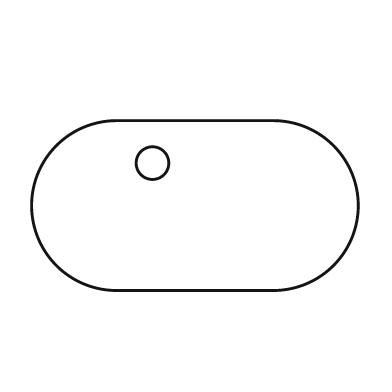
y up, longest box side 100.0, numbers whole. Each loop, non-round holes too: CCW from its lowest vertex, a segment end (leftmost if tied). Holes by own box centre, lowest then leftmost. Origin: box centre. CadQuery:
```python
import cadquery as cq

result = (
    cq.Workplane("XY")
    .moveTo(-24.0, -26.0)
    .lineTo(24.0, -26.0)
    .threePointArc((50.0, 0.0), (24.0, 26.0))
    .lineTo(-24.0, 26.0)
    .threePointArc((-50.0, 0.0), (-24.0, -26.0))
    .close()
    .moveTo(-13.0, 13.0)
    .circle(5.0)
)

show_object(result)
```